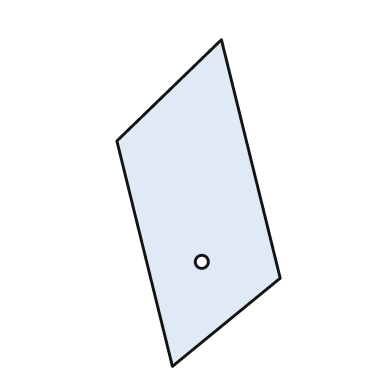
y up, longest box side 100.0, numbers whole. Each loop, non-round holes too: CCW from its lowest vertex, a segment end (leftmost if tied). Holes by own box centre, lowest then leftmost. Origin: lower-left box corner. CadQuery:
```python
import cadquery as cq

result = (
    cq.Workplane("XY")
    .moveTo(17.0, 0.0)
    .lineTo(50.0, 27.0)
    .lineTo(32.0, 100.0)
    .lineTo(0.0, 69.0)
    .close()
    .moveTo(26.0, 32.0)
    .circle(2.0)
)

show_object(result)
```